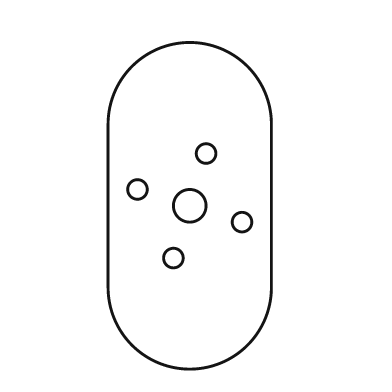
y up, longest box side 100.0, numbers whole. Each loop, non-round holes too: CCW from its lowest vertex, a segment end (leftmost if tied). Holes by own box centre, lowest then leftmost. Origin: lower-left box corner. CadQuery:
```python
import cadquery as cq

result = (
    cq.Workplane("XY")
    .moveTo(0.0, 25.0)
    .threePointArc((25.0, 0.0), (50.0, 25.0))
    .lineTo(50.0, 75.0)
    .threePointArc((25.0, 100.0), (0.0, 75.0))
    .close()
    .moveTo(20.0, 34.0)
    .circle(3.0)
    .moveTo(41.0, 45.0)
    .circle(3.0)
    .moveTo(25.0, 50.0)
    .circle(5.0)
    .moveTo(9.0, 55.0)
    .circle(3.0)
    .moveTo(30.0, 66.0)
    .circle(3.0)
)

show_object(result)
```